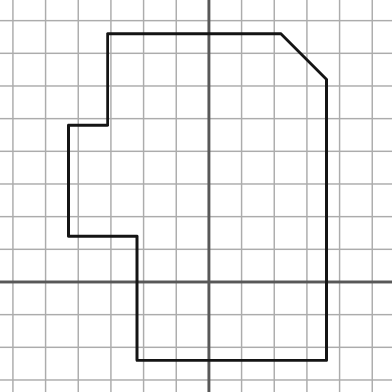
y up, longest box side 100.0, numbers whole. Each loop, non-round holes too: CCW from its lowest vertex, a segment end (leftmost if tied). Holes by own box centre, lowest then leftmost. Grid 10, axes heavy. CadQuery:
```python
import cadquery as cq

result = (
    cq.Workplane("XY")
    .moveTo(-22.0, -24.0)
    .lineTo(36.0, -24.0)
    .lineTo(36.0, 62.0)
    .lineTo(22.0, 76.0)
    .lineTo(-31.0, 76.0)
    .lineTo(-31.0, 48.0)
    .lineTo(-43.0, 48.0)
    .lineTo(-43.0, 14.0)
    .lineTo(-22.0, 14.0)
    .close()
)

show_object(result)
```